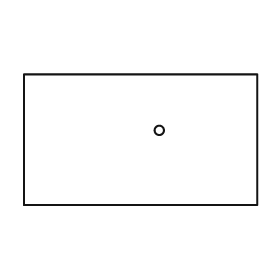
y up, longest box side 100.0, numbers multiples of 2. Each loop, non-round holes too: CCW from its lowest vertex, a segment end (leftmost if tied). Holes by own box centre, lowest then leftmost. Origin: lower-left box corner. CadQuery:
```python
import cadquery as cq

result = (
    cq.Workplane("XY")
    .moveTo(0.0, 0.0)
    .lineTo(100.0, 0.0)
    .lineTo(100.0, 56.0)
    .lineTo(0.0, 56.0)
    .close()
    .moveTo(58.0, 32.0)
    .circle(2.0)
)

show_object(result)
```